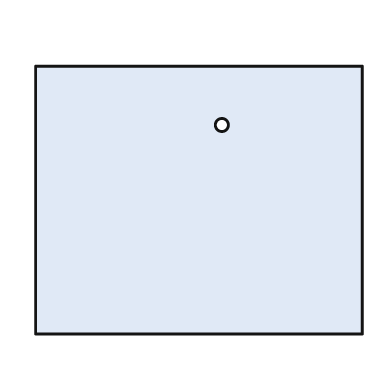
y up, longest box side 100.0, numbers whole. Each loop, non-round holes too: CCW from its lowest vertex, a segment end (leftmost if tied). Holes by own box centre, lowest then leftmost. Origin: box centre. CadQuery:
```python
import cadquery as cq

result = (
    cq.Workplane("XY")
    .moveTo(-50.0, -41.0)
    .lineTo(50.0, -41.0)
    .lineTo(50.0, 41.0)
    .lineTo(-50.0, 41.0)
    .close()
    .moveTo(7.0, 23.0)
    .circle(2.0)
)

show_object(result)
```